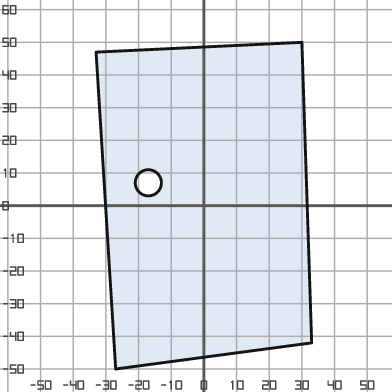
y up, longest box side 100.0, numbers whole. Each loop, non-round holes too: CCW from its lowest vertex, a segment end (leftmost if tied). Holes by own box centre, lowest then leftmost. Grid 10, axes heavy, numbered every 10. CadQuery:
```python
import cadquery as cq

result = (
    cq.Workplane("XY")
    .moveTo(-27.0, -50.0)
    .lineTo(33.0, -42.0)
    .lineTo(30.0, 50.0)
    .lineTo(-33.0, 47.0)
    .close()
    .moveTo(-17.0, 7.0)
    .circle(4.0)
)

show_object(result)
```